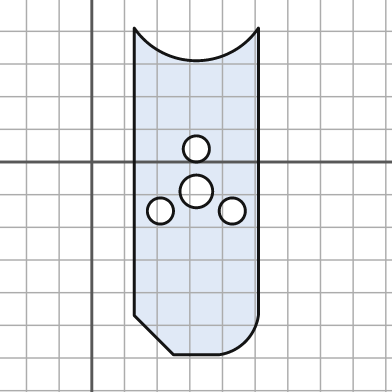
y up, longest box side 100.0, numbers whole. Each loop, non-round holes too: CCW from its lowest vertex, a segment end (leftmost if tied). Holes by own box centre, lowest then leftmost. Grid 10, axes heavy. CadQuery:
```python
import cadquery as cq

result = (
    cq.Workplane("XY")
    .moveTo(25.0, -59.0)
    .lineTo(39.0, -59.0)
    .threePointArc((47.0, -55.0), (51.0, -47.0))
    .lineTo(51.0, 41.0)
    .threePointArc((32.0, 31.0), (13.0, 41.0))
    .lineTo(13.0, -47.0)
    .close()
    .moveTo(21.0, -15.0)
    .circle(4.0)
    .moveTo(43.0, -15.0)
    .circle(4.0)
    .moveTo(32.0, -9.0)
    .circle(5.0)
    .moveTo(32.0, 4.0)
    .circle(4.0)
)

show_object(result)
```